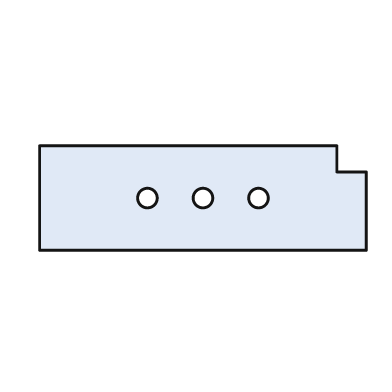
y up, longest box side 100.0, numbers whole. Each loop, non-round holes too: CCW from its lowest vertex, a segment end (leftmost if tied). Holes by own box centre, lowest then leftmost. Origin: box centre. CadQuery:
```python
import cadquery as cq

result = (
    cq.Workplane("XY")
    .moveTo(-50.0, -16.0)
    .lineTo(50.0, -16.0)
    .lineTo(50.0, 8.0)
    .lineTo(41.0, 8.0)
    .lineTo(41.0, 16.0)
    .lineTo(-50.0, 16.0)
    .close()
    .moveTo(-17.0, 0.0)
    .circle(3.0)
    .moveTo(0.0, 0.0)
    .circle(3.0)
    .moveTo(17.0, 0.0)
    .circle(3.0)
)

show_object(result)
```